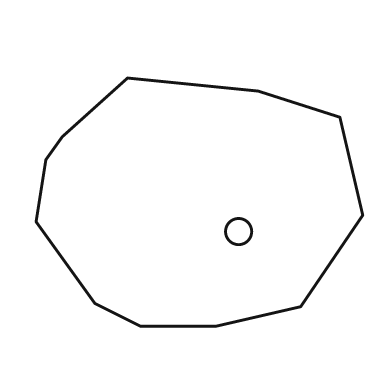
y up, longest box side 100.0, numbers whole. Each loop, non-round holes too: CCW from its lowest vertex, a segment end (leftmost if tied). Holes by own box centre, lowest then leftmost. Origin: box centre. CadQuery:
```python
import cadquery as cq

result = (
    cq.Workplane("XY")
    .moveTo(-18.0, -38.0)
    .lineTo(5.0, -38.0)
    .lineTo(31.0, -32.0)
    .lineTo(50.0, -4.0)
    .lineTo(43.0, 26.0)
    .lineTo(18.0, 34.0)
    .lineTo(-22.0, 38.0)
    .lineTo(-42.0, 20.0)
    .lineTo(-47.0, 13.0)
    .lineTo(-50.0, -6.0)
    .lineTo(-32.0, -31.0)
    .close()
    .moveTo(12.0, -9.0)
    .circle(4.0)
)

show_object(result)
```